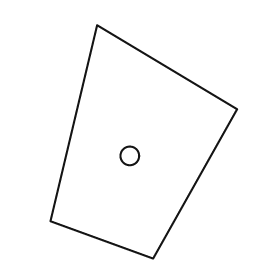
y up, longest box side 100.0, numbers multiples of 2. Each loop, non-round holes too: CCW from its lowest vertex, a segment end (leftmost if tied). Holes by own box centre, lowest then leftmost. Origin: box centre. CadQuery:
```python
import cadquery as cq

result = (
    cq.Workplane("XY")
    .moveTo(4.0, -50.0)
    .lineTo(40.0, 14.0)
    .lineTo(-20.0, 50.0)
    .lineTo(-40.0, -34.0)
    .close()
    .moveTo(-6.0, -6.0)
    .circle(4.0)
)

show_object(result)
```